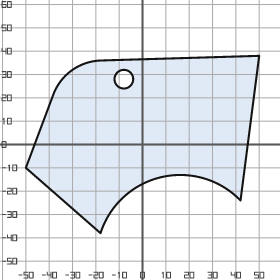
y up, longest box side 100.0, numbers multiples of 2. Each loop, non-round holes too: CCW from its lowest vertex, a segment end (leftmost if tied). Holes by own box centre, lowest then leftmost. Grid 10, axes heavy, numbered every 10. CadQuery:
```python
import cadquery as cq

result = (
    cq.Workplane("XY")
    .moveTo(-18.0, -38.0)
    .threePointArc((8.0, -14.0), (42.0, -24.0))
    .lineTo(50.0, 38.0)
    .lineTo(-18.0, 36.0)
    .threePointArc((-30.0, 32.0), (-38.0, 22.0))
    .lineTo(-50.0, -10.0)
    .close()
    .moveTo(-8.0, 28.0)
    .circle(4.0)
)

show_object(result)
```